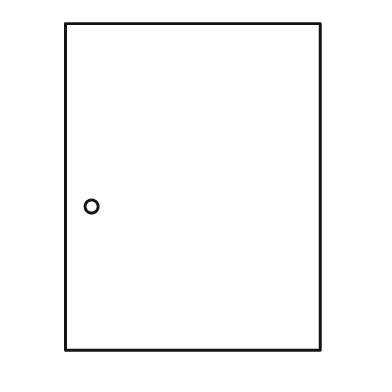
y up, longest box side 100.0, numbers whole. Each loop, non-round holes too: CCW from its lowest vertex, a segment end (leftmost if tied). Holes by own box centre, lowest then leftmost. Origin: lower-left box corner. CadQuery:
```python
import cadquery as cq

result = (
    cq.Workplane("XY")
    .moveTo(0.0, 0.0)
    .lineTo(78.0, 0.0)
    .lineTo(78.0, 100.0)
    .lineTo(0.0, 100.0)
    .close()
    .moveTo(8.0, 44.0)
    .circle(2.0)
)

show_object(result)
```